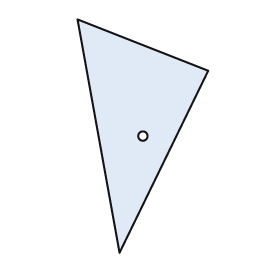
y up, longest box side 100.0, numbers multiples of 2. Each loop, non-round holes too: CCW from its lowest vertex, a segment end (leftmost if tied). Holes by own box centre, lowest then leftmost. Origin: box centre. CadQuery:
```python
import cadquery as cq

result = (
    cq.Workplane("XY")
    .moveTo(-10.0, -50.0)
    .lineTo(28.0, 28.0)
    .lineTo(-28.0, 50.0)
    .close()
    .moveTo(0.0, 0.0)
    .circle(2.0)
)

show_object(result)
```